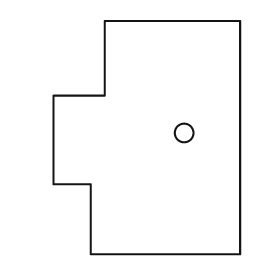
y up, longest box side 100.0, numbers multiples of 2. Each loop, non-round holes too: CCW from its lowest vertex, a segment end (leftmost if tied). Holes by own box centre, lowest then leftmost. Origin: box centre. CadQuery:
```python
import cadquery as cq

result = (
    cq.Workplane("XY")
    .moveTo(-24.0, -50.0)
    .lineTo(40.0, -50.0)
    .lineTo(40.0, 50.0)
    .lineTo(-18.0, 50.0)
    .lineTo(-18.0, 18.0)
    .lineTo(-40.0, 18.0)
    .lineTo(-40.0, -20.0)
    .lineTo(-24.0, -20.0)
    .close()
    .moveTo(16.0, 2.0)
    .circle(4.0)
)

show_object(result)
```